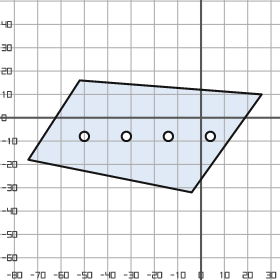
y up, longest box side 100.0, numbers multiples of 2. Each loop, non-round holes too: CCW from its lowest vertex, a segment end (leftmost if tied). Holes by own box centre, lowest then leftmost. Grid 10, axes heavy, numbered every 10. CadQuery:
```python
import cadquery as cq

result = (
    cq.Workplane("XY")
    .moveTo(-4.0, -32.0)
    .lineTo(26.0, 10.0)
    .lineTo(-52.0, 16.0)
    .lineTo(-74.0, -18.0)
    .close()
    .moveTo(-50.0, -8.0)
    .circle(2.0)
    .moveTo(-32.0, -8.0)
    .circle(2.0)
    .moveTo(-14.0, -8.0)
    .circle(2.0)
    .moveTo(4.0, -8.0)
    .circle(2.0)
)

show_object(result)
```